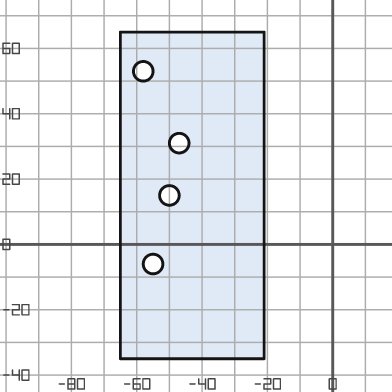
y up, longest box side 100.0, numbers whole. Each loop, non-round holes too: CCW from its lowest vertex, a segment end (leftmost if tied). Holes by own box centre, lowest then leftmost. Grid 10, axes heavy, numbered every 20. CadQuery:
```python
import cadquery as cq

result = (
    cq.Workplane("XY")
    .moveTo(-65.0, -35.0)
    .lineTo(-21.0, -35.0)
    .lineTo(-21.0, 65.0)
    .lineTo(-65.0, 65.0)
    .close()
    .moveTo(-55.0, -6.0)
    .circle(3.0)
    .moveTo(-50.0, 15.0)
    .circle(3.0)
    .moveTo(-47.0, 31.0)
    .circle(3.0)
    .moveTo(-58.0, 53.0)
    .circle(3.0)
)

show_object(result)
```